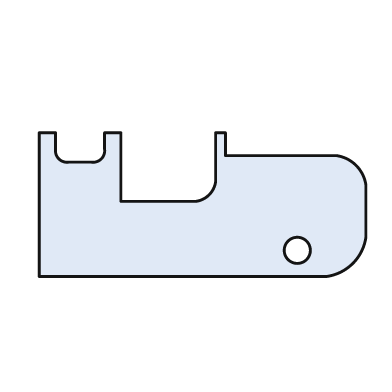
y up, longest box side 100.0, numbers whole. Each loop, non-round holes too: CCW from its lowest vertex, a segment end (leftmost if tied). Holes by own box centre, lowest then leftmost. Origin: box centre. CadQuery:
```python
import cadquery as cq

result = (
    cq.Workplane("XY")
    .moveTo(-50.0, -22.0)
    .lineTo(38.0, -22.0)
    .threePointArc((46.0, -18.0), (50.0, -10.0))
    .lineTo(50.0, 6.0)
    .threePointArc((47.0, 12.0), (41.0, 15.0))
    .lineTo(7.0, 15.0)
    .lineTo(7.0, 22.0)
    .lineTo(4.0, 22.0)
    .lineTo(4.0, 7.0)
    .threePointArc((2.0, 3.0), (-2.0, 1.0))
    .lineTo(-25.0, 1.0)
    .lineTo(-25.0, 22.0)
    .lineTo(-30.0, 22.0)
    .lineTo(-30.0, 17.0)
    .threePointArc((-31.0, 14.0), (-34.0, 13.0))
    .lineTo(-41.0, 13.0)
    .threePointArc((-44.0, 14.0), (-45.0, 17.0))
    .lineTo(-45.0, 22.0)
    .lineTo(-50.0, 22.0)
    .close()
    .moveTo(29.0, -14.0)
    .circle(4.0)
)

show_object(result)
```